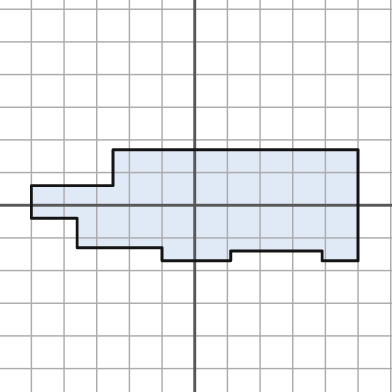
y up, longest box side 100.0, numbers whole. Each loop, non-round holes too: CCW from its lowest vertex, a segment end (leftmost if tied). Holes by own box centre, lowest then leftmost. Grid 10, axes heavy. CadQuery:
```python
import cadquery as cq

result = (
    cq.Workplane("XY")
    .moveTo(-10.0, -17.0)
    .lineTo(11.0, -17.0)
    .lineTo(11.0, -14.0)
    .lineTo(39.0, -14.0)
    .lineTo(39.0, -17.0)
    .lineTo(50.0, -17.0)
    .lineTo(50.0, 17.0)
    .lineTo(-25.0, 17.0)
    .lineTo(-25.0, 6.0)
    .lineTo(-50.0, 6.0)
    .lineTo(-50.0, -4.0)
    .lineTo(-36.0, -4.0)
    .lineTo(-36.0, -13.0)
    .lineTo(-10.0, -13.0)
    .close()
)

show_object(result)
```